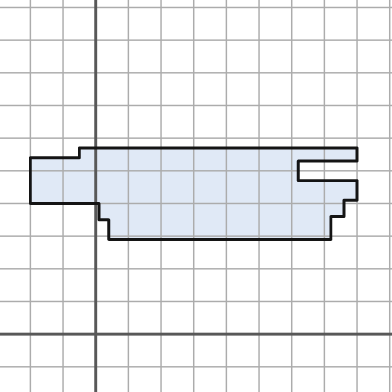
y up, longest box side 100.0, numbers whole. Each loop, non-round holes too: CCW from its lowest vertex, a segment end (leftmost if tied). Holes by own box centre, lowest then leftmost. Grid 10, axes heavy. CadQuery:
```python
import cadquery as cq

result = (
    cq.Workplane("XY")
    .moveTo(4.0, 29.0)
    .lineTo(72.0, 29.0)
    .lineTo(72.0, 36.0)
    .lineTo(76.0, 36.0)
    .lineTo(76.0, 41.0)
    .lineTo(80.0, 41.0)
    .lineTo(80.0, 47.0)
    .lineTo(62.0, 47.0)
    .lineTo(62.0, 53.0)
    .lineTo(80.0, 53.0)
    .lineTo(80.0, 57.0)
    .lineTo(-5.0, 57.0)
    .lineTo(-5.0, 54.0)
    .lineTo(-20.0, 54.0)
    .lineTo(-20.0, 40.0)
    .lineTo(1.0, 40.0)
    .lineTo(1.0, 35.0)
    .lineTo(4.0, 35.0)
    .close()
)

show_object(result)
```